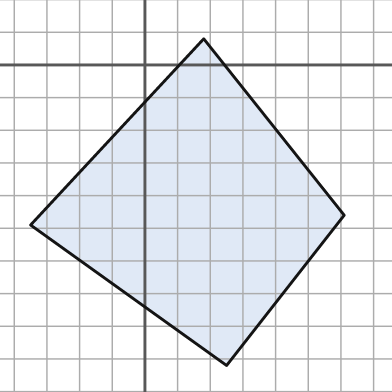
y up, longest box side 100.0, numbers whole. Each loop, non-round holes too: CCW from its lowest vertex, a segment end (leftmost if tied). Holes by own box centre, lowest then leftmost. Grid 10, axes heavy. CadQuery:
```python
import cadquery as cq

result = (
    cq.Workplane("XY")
    .moveTo(25.0, -92.0)
    .lineTo(61.0, -46.0)
    .lineTo(18.0, 8.0)
    .lineTo(-35.0, -49.0)
    .close()
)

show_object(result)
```